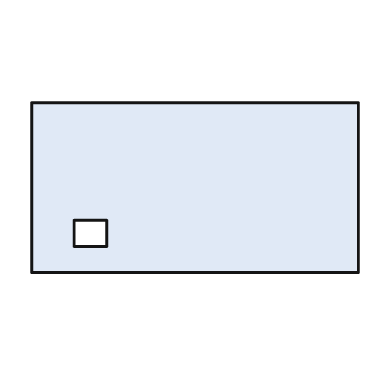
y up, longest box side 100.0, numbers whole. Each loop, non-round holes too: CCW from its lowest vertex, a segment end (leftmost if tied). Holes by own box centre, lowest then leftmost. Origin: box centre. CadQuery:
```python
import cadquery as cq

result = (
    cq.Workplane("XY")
    .moveTo(-50.0, -26.0)
    .lineTo(50.0, -26.0)
    .lineTo(50.0, 26.0)
    .lineTo(-50.0, 26.0)
    .close()
    .moveTo(-37.0, -18.0)
    .lineTo(-27.0, -18.0)
    .lineTo(-27.0, -10.0)
    .lineTo(-37.0, -10.0)
    .close()
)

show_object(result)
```